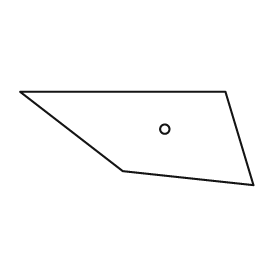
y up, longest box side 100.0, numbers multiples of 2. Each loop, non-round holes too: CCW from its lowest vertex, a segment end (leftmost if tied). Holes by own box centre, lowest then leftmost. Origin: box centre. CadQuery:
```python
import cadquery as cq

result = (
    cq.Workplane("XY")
    .moveTo(50.0, -20.0)
    .lineTo(38.0, 20.0)
    .lineTo(-50.0, 20.0)
    .lineTo(-6.0, -14.0)
    .close()
    .moveTo(12.0, 4.0)
    .circle(2.0)
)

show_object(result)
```